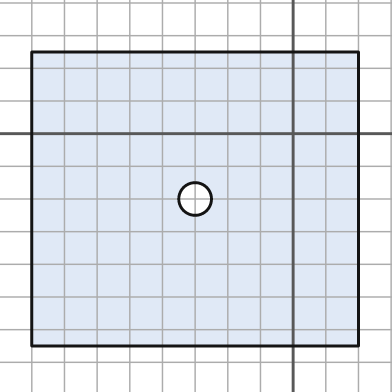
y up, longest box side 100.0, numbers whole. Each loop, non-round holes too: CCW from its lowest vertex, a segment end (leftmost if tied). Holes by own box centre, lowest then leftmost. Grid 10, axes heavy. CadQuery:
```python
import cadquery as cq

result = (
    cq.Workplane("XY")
    .moveTo(-80.0, -65.0)
    .lineTo(20.0, -65.0)
    .lineTo(20.0, 25.0)
    .lineTo(-80.0, 25.0)
    .close()
    .moveTo(-30.0, -20.0)
    .circle(5.0)
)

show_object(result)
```